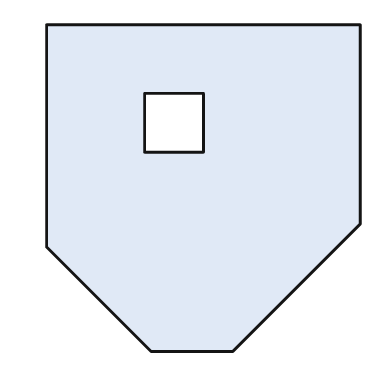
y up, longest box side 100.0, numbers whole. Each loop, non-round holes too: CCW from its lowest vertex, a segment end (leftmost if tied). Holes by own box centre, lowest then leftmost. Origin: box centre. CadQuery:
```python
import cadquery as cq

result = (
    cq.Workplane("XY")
    .moveTo(-16.0, -50.0)
    .lineTo(9.0, -50.0)
    .lineTo(48.0, -11.0)
    .lineTo(48.0, 50.0)
    .lineTo(-48.0, 50.0)
    .lineTo(-48.0, -18.0)
    .close()
    .moveTo(-18.0, 11.0)
    .lineTo(0.0, 11.0)
    .lineTo(0.0, 29.0)
    .lineTo(-18.0, 29.0)
    .close()
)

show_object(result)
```